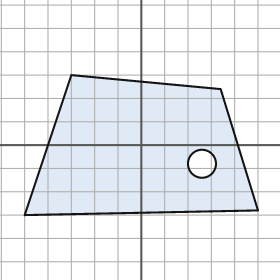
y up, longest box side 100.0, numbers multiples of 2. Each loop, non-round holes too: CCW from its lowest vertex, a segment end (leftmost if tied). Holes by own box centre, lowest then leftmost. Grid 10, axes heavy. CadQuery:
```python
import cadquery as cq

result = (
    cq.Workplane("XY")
    .moveTo(-50.0, -30.0)
    .lineTo(50.0, -28.0)
    .lineTo(34.0, 24.0)
    .lineTo(-30.0, 30.0)
    .close()
    .moveTo(26.0, -8.0)
    .circle(6.0)
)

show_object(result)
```